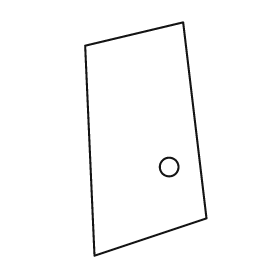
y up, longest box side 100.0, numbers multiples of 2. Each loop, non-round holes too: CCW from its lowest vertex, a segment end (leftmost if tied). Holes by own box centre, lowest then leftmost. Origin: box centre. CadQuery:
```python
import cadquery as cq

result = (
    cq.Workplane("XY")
    .moveTo(-22.0, -50.0)
    .lineTo(26.0, -34.0)
    .lineTo(16.0, 50.0)
    .lineTo(-26.0, 40.0)
    .close()
    .moveTo(10.0, -12.0)
    .circle(4.0)
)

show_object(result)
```